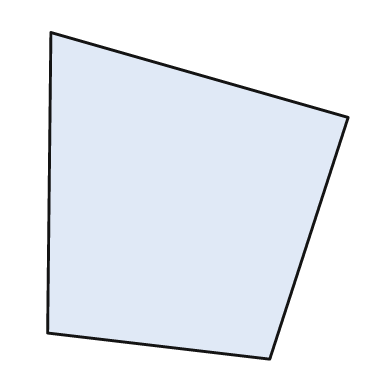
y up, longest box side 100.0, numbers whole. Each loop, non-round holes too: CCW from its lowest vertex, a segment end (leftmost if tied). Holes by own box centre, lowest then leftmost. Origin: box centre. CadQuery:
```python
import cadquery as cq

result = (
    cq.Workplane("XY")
    .moveTo(22.0, -50.0)
    .lineTo(46.0, 24.0)
    .lineTo(-45.0, 50.0)
    .lineTo(-46.0, -42.0)
    .close()
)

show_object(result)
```